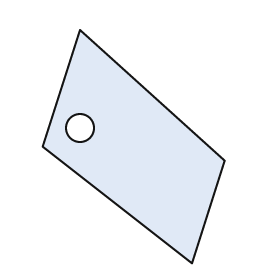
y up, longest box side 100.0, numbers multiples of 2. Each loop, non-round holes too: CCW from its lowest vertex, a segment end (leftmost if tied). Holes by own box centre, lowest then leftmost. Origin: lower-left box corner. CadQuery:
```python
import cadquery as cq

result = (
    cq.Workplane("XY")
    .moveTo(64.0, 0.0)
    .lineTo(78.0, 44.0)
    .lineTo(16.0, 100.0)
    .lineTo(0.0, 50.0)
    .close()
    .moveTo(16.0, 58.0)
    .circle(6.0)
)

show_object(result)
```